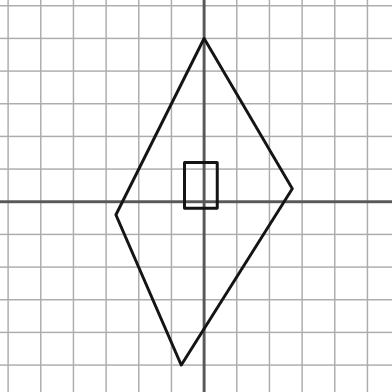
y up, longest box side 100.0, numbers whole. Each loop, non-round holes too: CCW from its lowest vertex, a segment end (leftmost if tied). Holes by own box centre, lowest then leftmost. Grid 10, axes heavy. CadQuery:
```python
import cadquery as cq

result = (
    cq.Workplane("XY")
    .moveTo(-7.0, -50.0)
    .lineTo(27.0, 4.0)
    .lineTo(0.0, 50.0)
    .lineTo(-27.0, -4.0)
    .close()
    .moveTo(-6.0, -2.0)
    .lineTo(4.0, -2.0)
    .lineTo(4.0, 12.0)
    .lineTo(-6.0, 12.0)
    .close()
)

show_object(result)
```